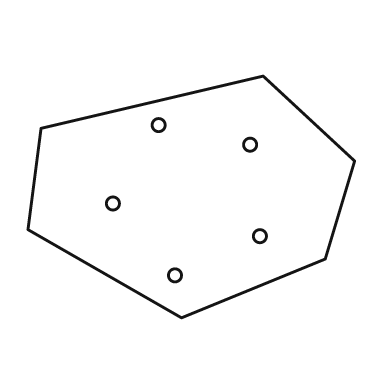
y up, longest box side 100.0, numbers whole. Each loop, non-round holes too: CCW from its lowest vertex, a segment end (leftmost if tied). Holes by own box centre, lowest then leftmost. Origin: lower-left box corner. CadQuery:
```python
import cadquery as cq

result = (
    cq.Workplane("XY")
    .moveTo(47.0, 0.0)
    .lineTo(91.0, 18.0)
    .lineTo(100.0, 48.0)
    .lineTo(72.0, 74.0)
    .lineTo(4.0, 58.0)
    .lineTo(0.0, 27.0)
    .close()
    .moveTo(45.0, 13.0)
    .circle(2.0)
    .moveTo(71.0, 25.0)
    .circle(2.0)
    .moveTo(26.0, 35.0)
    .circle(2.0)
    .moveTo(68.0, 53.0)
    .circle(2.0)
    .moveTo(40.0, 59.0)
    .circle(2.0)
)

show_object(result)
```